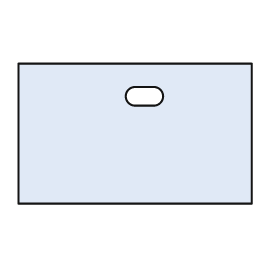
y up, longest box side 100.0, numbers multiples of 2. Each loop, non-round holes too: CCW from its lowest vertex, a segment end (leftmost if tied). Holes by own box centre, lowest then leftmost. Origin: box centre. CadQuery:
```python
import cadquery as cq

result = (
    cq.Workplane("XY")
    .moveTo(-50.0, -30.0)
    .lineTo(50.0, -30.0)
    .lineTo(50.0, 30.0)
    .lineTo(-50.0, 30.0)
    .close()
    .moveTo(0.0, 12.0)
    .lineTo(8.0, 12.0)
    .threePointArc((12.0, 16.0), (8.0, 20.0))
    .lineTo(0.0, 20.0)
    .threePointArc((-4.0, 16.0), (0.0, 12.0))
    .close()
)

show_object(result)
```